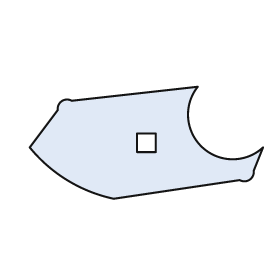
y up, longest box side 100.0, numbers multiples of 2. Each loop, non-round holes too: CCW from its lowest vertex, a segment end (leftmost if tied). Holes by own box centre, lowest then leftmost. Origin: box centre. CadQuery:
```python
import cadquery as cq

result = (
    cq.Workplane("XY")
    .moveTo(-14.0, -24.0)
    .lineTo(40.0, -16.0)
    .threePointArc((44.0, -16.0), (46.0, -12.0))
    .lineTo(50.0, -2.0)
    .threePointArc((24.0, -2.0), (22.0, 24.0))
    .lineTo(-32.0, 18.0)
    .threePointArc((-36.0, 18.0), (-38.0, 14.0))
    .lineTo(-50.0, -2.0)
    .threePointArc((-34.0, -16.0), (-14.0, -24.0))
    .close()
    .moveTo(-4.0, -4.0)
    .lineTo(4.0, -4.0)
    .lineTo(4.0, 4.0)
    .lineTo(-4.0, 4.0)
    .close()
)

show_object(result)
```